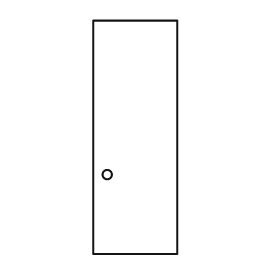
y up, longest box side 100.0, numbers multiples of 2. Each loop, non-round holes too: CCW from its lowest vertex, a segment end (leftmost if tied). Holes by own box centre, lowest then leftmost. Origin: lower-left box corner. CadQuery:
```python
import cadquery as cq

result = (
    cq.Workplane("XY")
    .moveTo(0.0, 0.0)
    .lineTo(36.0, 0.0)
    .lineTo(36.0, 100.0)
    .lineTo(0.0, 100.0)
    .close()
    .moveTo(6.0, 34.0)
    .circle(2.0)
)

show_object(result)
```